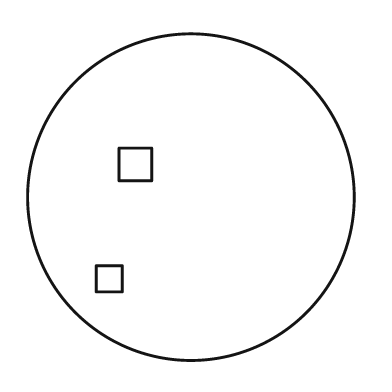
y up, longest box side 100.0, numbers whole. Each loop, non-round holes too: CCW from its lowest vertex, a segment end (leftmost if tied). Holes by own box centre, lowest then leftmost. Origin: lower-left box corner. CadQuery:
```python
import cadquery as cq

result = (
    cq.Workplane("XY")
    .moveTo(50.0, 50.0)
    .circle(50.0)
    .moveTo(21.0, 21.0)
    .lineTo(29.0, 21.0)
    .lineTo(29.0, 29.0)
    .lineTo(21.0, 29.0)
    .close()
    .moveTo(28.0, 55.0)
    .lineTo(38.0, 55.0)
    .lineTo(38.0, 65.0)
    .lineTo(28.0, 65.0)
    .close()
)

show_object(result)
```